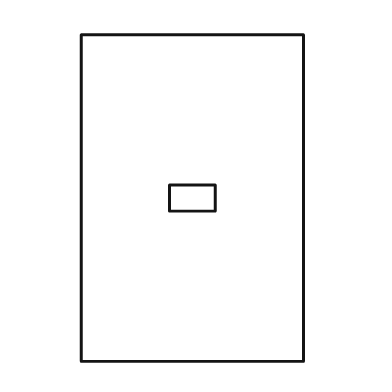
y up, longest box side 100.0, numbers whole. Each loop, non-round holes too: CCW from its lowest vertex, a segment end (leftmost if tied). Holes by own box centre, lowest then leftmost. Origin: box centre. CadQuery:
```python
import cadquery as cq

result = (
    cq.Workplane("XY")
    .moveTo(-34.0, -50.0)
    .lineTo(34.0, -50.0)
    .lineTo(34.0, 50.0)
    .lineTo(-34.0, 50.0)
    .close()
    .moveTo(-7.0, -4.0)
    .lineTo(7.0, -4.0)
    .lineTo(7.0, 4.0)
    .lineTo(-7.0, 4.0)
    .close()
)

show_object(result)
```